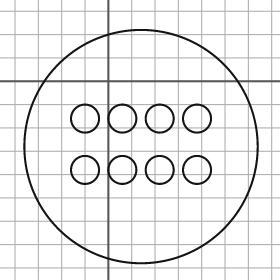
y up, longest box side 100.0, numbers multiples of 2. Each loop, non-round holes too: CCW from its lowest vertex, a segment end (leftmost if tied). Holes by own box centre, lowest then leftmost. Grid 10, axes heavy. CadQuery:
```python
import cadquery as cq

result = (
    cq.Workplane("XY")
    .moveTo(14.0, -28.0)
    .circle(50.0)
    .moveTo(-10.0, -38.0)
    .circle(6.0)
    .moveTo(6.0, -38.0)
    .circle(6.0)
    .moveTo(22.0, -38.0)
    .circle(6.0)
    .moveTo(38.0, -38.0)
    .circle(6.0)
    .moveTo(-10.0, -16.0)
    .circle(6.0)
    .moveTo(6.0, -16.0)
    .circle(6.0)
    .moveTo(22.0, -16.0)
    .circle(6.0)
    .moveTo(38.0, -16.0)
    .circle(6.0)
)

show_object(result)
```